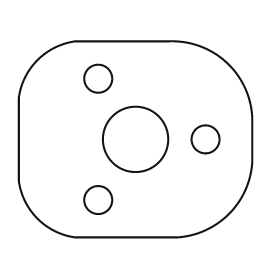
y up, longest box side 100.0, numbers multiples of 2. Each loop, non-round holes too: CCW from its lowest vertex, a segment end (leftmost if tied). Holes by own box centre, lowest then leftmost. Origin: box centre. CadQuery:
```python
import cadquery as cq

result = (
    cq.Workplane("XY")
    .moveTo(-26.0, -42.0)
    .lineTo(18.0, -42.0)
    .threePointArc((40.0, -32.0), (50.0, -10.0))
    .lineTo(50.0, 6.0)
    .threePointArc((40.0, 32.0), (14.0, 42.0))
    .lineTo(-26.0, 42.0)
    .threePointArc((-42.0, 34.0), (-50.0, 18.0))
    .lineTo(-50.0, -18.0)
    .threePointArc((-42.0, -34.0), (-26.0, -42.0))
    .close()
    .moveTo(-16.0, -26.0)
    .circle(6.0)
    .moveTo(0.0, 0.0)
    .circle(14.0)
    .moveTo(30.0, 0.0)
    .circle(6.0)
    .moveTo(-16.0, 26.0)
    .circle(6.0)
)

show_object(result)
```